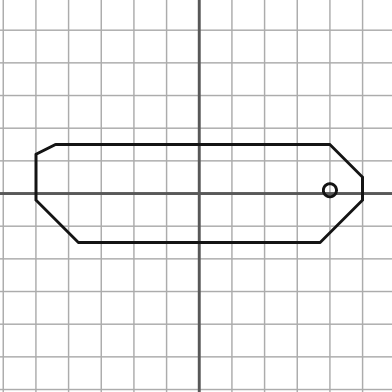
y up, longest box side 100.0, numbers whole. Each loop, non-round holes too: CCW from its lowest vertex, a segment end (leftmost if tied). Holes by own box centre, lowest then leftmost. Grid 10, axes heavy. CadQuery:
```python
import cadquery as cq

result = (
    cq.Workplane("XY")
    .moveTo(-37.0, -15.0)
    .lineTo(37.0, -15.0)
    .lineTo(50.0, -2.0)
    .lineTo(50.0, 5.0)
    .lineTo(40.0, 15.0)
    .lineTo(-44.0, 15.0)
    .lineTo(-50.0, 12.0)
    .lineTo(-50.0, -2.0)
    .close()
    .moveTo(40.0, 1.0)
    .circle(2.0)
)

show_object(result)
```